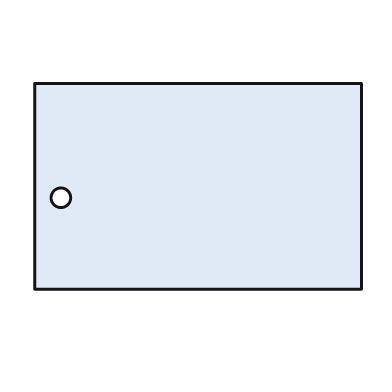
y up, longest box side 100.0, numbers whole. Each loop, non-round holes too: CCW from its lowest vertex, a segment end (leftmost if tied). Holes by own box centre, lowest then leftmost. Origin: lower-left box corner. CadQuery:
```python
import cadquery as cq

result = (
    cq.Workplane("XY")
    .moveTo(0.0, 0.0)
    .lineTo(100.0, 0.0)
    .lineTo(100.0, 63.0)
    .lineTo(0.0, 63.0)
    .close()
    .moveTo(8.0, 28.0)
    .circle(3.0)
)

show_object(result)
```